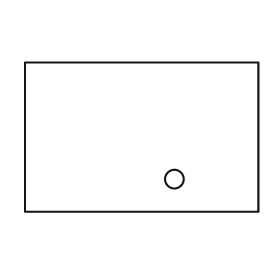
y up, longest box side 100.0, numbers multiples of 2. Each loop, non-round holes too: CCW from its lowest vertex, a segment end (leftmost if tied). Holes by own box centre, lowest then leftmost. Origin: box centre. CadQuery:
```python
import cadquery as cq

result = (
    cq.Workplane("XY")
    .moveTo(-50.0, -32.0)
    .lineTo(50.0, -32.0)
    .lineTo(50.0, 32.0)
    .lineTo(-50.0, 32.0)
    .close()
    .moveTo(14.0, -18.0)
    .circle(4.0)
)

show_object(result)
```